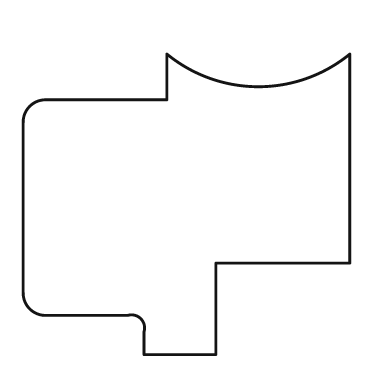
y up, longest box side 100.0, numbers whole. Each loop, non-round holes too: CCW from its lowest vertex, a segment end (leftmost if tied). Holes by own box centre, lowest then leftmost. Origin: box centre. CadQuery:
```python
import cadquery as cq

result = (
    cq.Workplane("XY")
    .moveTo(-13.0, -46.0)
    .lineTo(9.0, -46.0)
    .lineTo(9.0, -18.0)
    .lineTo(50.0, -18.0)
    .lineTo(50.0, 46.0)
    .threePointArc((22.0, 36.0), (-6.0, 46.0))
    .lineTo(-6.0, 32.0)
    .lineTo(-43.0, 32.0)
    .threePointArc((-48.0, 30.0), (-50.0, 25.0))
    .lineTo(-50.0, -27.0)
    .threePointArc((-48.0, -32.0), (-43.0, -34.0))
    .lineTo(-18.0, -34.0)
    .threePointArc((-14.0, -35.0), (-13.0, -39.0))
    .close()
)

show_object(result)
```